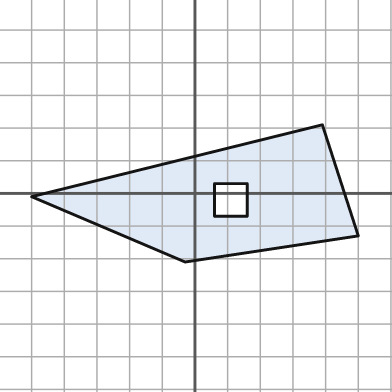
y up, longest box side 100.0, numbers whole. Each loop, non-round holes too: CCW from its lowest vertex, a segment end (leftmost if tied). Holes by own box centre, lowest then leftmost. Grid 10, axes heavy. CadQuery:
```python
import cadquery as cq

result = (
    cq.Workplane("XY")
    .moveTo(-3.0, -21.0)
    .lineTo(50.0, -13.0)
    .lineTo(39.0, 21.0)
    .lineTo(-50.0, -1.0)
    .close()
    .moveTo(6.0, -7.0)
    .lineTo(16.0, -7.0)
    .lineTo(16.0, 3.0)
    .lineTo(6.0, 3.0)
    .close()
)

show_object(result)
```